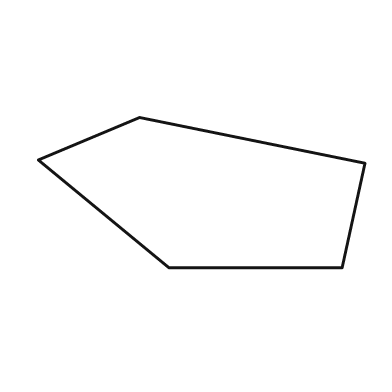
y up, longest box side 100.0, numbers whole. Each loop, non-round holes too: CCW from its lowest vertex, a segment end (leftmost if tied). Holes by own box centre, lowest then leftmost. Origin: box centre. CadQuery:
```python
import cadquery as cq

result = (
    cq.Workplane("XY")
    .moveTo(-10.0, -23.0)
    .lineTo(43.0, -23.0)
    .lineTo(50.0, 9.0)
    .lineTo(-19.0, 23.0)
    .lineTo(-50.0, 10.0)
    .close()
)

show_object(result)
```